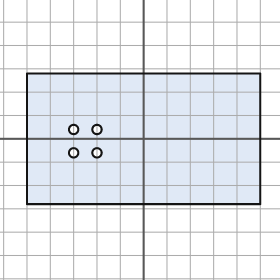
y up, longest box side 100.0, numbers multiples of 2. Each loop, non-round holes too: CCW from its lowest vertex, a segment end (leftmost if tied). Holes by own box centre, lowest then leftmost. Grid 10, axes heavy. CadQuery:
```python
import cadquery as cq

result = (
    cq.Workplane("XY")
    .moveTo(-50.0, -28.0)
    .lineTo(50.0, -28.0)
    .lineTo(50.0, 28.0)
    .lineTo(-50.0, 28.0)
    .close()
    .moveTo(-30.0, -6.0)
    .circle(2.0)
    .moveTo(-20.0, -6.0)
    .circle(2.0)
    .moveTo(-30.0, 4.0)
    .circle(2.0)
    .moveTo(-20.0, 4.0)
    .circle(2.0)
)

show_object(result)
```